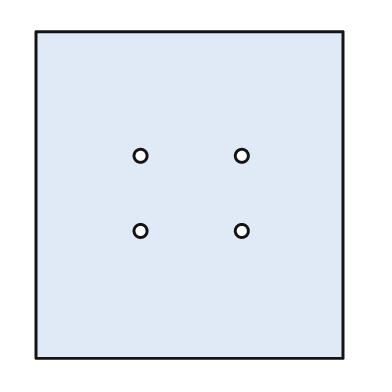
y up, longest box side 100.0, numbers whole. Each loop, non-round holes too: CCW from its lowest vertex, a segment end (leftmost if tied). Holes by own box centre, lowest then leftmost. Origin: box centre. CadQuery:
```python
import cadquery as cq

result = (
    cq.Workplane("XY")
    .moveTo(-47.0, -50.0)
    .lineTo(47.0, -50.0)
    .lineTo(47.0, 50.0)
    .lineTo(-47.0, 50.0)
    .close()
    .moveTo(-15.0, -11.0)
    .circle(2.0)
    .moveTo(16.0, -11.0)
    .circle(2.0)
    .moveTo(-15.0, 12.0)
    .circle(2.0)
    .moveTo(16.0, 12.0)
    .circle(2.0)
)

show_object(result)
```